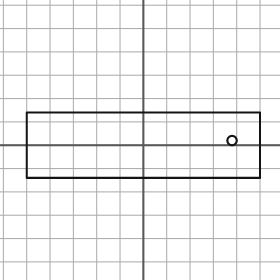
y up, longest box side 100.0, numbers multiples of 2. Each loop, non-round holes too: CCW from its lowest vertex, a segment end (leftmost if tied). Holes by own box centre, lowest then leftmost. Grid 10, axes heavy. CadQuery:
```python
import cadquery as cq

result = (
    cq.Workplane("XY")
    .moveTo(-50.0, -14.0)
    .lineTo(50.0, -14.0)
    .lineTo(50.0, 14.0)
    .lineTo(-50.0, 14.0)
    .close()
    .moveTo(38.0, 2.0)
    .circle(2.0)
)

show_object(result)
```